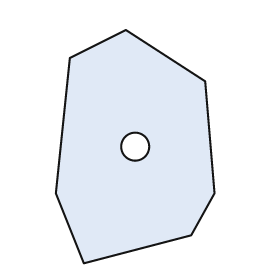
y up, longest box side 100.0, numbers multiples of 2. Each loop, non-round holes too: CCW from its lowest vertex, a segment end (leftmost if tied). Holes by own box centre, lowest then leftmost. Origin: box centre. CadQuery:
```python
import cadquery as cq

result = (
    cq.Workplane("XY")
    .moveTo(-22.0, -50.0)
    .lineTo(24.0, -38.0)
    .lineTo(34.0, -20.0)
    .lineTo(30.0, 28.0)
    .lineTo(-4.0, 50.0)
    .lineTo(-28.0, 38.0)
    .lineTo(-34.0, -20.0)
    .close()
    .moveTo(0.0, 0.0)
    .circle(6.0)
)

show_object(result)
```